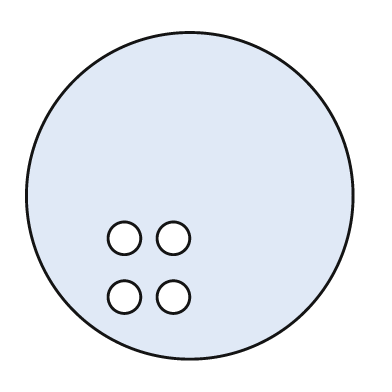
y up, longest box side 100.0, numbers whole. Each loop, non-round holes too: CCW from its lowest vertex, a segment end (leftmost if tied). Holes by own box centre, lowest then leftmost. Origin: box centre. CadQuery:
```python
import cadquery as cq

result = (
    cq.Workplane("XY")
    .moveTo(0.0, 0.0)
    .circle(50.0)
    .moveTo(-20.0, -31.0)
    .circle(5.0)
    .moveTo(-5.0, -31.0)
    .circle(5.0)
    .moveTo(-20.0, -13.0)
    .circle(5.0)
    .moveTo(-5.0, -13.0)
    .circle(5.0)
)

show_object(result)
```